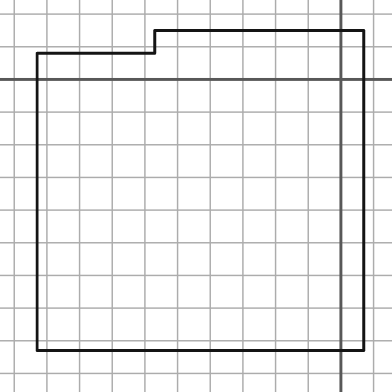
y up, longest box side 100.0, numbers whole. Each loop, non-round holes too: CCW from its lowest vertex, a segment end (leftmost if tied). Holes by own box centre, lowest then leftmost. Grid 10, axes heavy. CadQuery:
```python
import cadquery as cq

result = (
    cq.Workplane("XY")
    .moveTo(-93.0, -83.0)
    .lineTo(7.0, -83.0)
    .lineTo(7.0, 15.0)
    .lineTo(-57.0, 15.0)
    .lineTo(-57.0, 8.0)
    .lineTo(-93.0, 8.0)
    .close()
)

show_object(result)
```